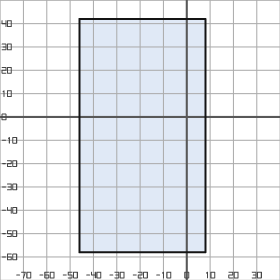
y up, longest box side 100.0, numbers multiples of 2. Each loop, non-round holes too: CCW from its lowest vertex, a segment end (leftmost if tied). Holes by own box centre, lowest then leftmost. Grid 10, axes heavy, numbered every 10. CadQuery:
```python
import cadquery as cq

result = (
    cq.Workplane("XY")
    .moveTo(-46.0, -58.0)
    .lineTo(8.0, -58.0)
    .lineTo(8.0, 42.0)
    .lineTo(-46.0, 42.0)
    .close()
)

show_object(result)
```